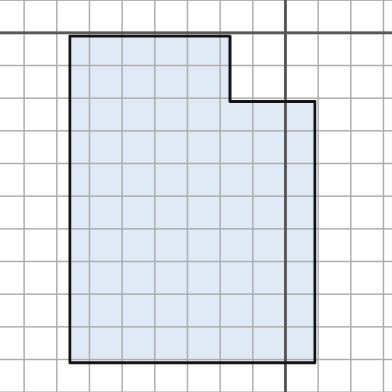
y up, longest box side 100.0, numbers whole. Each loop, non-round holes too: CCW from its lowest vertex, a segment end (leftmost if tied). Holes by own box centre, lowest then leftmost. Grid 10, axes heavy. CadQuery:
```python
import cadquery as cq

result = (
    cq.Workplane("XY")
    .moveTo(-66.0, -101.0)
    .lineTo(9.0, -101.0)
    .lineTo(9.0, -21.0)
    .lineTo(-17.0, -21.0)
    .lineTo(-17.0, -1.0)
    .lineTo(-66.0, -1.0)
    .close()
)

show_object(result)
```